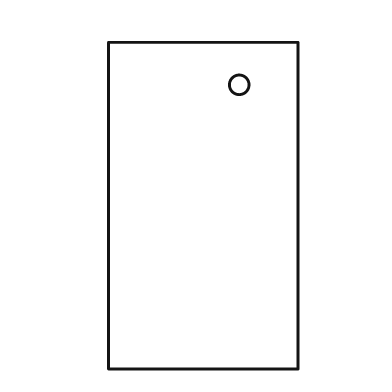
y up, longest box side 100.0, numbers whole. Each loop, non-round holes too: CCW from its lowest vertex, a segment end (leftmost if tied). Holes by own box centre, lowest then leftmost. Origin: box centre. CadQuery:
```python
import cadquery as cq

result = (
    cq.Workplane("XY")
    .moveTo(-29.0, -50.0)
    .lineTo(29.0, -50.0)
    .lineTo(29.0, 50.0)
    .lineTo(-29.0, 50.0)
    .close()
    .moveTo(11.0, 37.0)
    .circle(3.0)
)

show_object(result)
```